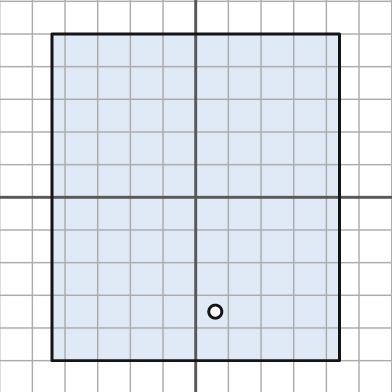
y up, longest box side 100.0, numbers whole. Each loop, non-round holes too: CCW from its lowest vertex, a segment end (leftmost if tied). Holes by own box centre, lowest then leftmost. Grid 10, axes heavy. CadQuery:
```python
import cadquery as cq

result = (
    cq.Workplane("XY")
    .moveTo(-44.0, -50.0)
    .lineTo(44.0, -50.0)
    .lineTo(44.0, 50.0)
    .lineTo(-44.0, 50.0)
    .close()
    .moveTo(6.0, -35.0)
    .circle(2.0)
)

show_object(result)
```